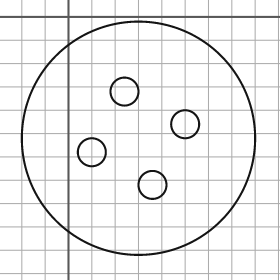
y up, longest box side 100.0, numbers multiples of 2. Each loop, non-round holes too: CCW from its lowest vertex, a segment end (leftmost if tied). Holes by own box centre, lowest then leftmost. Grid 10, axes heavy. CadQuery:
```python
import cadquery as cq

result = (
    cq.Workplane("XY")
    .moveTo(30.0, -52.0)
    .circle(50.0)
    .moveTo(36.0, -72.0)
    .circle(6.0)
    .moveTo(10.0, -58.0)
    .circle(6.0)
    .moveTo(50.0, -46.0)
    .circle(6.0)
    .moveTo(24.0, -32.0)
    .circle(6.0)
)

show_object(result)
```